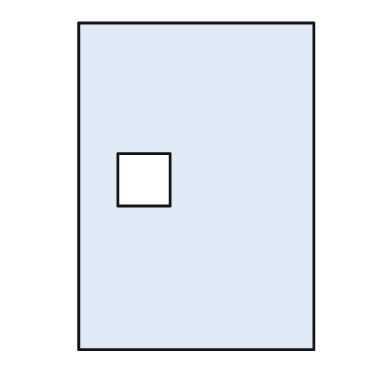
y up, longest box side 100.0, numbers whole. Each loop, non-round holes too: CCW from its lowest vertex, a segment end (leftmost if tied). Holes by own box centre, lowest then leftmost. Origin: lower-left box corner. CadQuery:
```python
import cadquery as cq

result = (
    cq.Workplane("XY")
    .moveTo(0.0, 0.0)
    .lineTo(72.0, 0.0)
    .lineTo(72.0, 100.0)
    .lineTo(0.0, 100.0)
    .close()
    .moveTo(12.0, 44.0)
    .lineTo(28.0, 44.0)
    .lineTo(28.0, 60.0)
    .lineTo(12.0, 60.0)
    .close()
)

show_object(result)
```